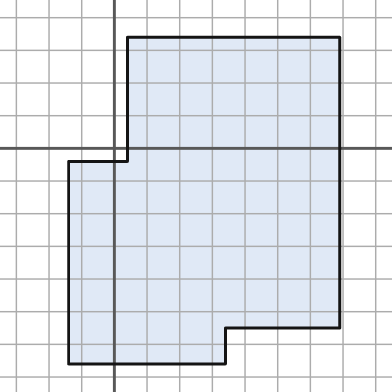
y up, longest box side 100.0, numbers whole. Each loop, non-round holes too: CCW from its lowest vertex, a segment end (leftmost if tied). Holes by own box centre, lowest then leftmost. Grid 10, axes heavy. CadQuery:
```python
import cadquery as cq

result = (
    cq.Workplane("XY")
    .moveTo(-14.0, -66.0)
    .lineTo(34.0, -66.0)
    .lineTo(34.0, -55.0)
    .lineTo(69.0, -55.0)
    .lineTo(69.0, 34.0)
    .lineTo(4.0, 34.0)
    .lineTo(4.0, -4.0)
    .lineTo(-14.0, -4.0)
    .close()
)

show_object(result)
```